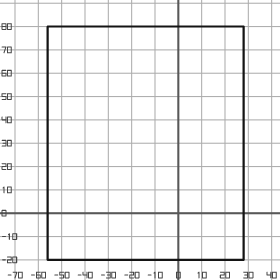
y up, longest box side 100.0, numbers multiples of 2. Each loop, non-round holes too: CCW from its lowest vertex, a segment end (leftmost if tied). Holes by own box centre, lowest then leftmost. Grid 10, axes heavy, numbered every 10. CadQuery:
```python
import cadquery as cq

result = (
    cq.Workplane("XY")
    .moveTo(-56.0, -20.0)
    .lineTo(28.0, -20.0)
    .lineTo(28.0, 80.0)
    .lineTo(-56.0, 80.0)
    .close()
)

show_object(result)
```